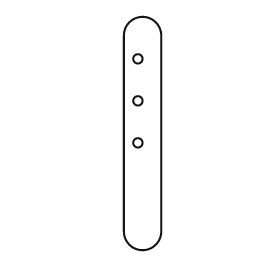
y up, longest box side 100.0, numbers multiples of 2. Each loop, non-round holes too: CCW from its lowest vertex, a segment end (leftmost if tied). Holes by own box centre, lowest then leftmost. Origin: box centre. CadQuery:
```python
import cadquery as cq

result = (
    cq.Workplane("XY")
    .moveTo(-8.0, -42.0)
    .threePointArc((0.0, -50.0), (8.0, -42.0))
    .lineTo(8.0, 42.0)
    .threePointArc((0.0, 50.0), (-8.0, 42.0))
    .close()
    .moveTo(-2.0, -4.0)
    .circle(2.0)
    .moveTo(-2.0, 14.0)
    .circle(2.0)
    .moveTo(-2.0, 32.0)
    .circle(2.0)
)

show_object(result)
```